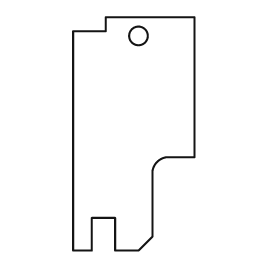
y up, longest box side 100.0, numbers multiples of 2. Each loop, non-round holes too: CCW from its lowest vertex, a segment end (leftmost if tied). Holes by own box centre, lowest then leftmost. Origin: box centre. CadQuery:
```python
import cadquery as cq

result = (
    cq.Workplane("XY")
    .moveTo(-26.0, -50.0)
    .lineTo(-18.0, -50.0)
    .lineTo(-18.0, -36.0)
    .lineTo(-8.0, -36.0)
    .lineTo(-8.0, -50.0)
    .lineTo(2.0, -50.0)
    .lineTo(8.0, -44.0)
    .lineTo(8.0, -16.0)
    .threePointArc((10.0, -12.0), (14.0, -10.0))
    .lineTo(26.0, -10.0)
    .lineTo(26.0, 50.0)
    .lineTo(-12.0, 50.0)
    .lineTo(-12.0, 44.0)
    .lineTo(-26.0, 44.0)
    .close()
    .moveTo(2.0, 42.0)
    .circle(4.0)
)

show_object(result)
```